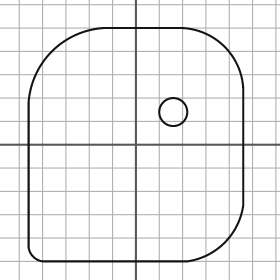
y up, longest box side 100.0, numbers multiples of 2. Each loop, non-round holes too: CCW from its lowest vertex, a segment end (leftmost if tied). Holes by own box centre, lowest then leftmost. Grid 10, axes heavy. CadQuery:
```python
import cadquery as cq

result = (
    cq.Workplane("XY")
    .moveTo(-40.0, -50.0)
    .lineTo(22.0, -50.0)
    .threePointArc((38.0, -42.0), (46.0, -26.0))
    .lineTo(46.0, 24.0)
    .threePointArc((38.0, 42.0), (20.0, 50.0))
    .lineTo(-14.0, 50.0)
    .threePointArc((-36.0, 40.0), (-46.0, 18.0))
    .lineTo(-46.0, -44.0)
    .threePointArc((-44.0, -48.0), (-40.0, -50.0))
    .close()
    .moveTo(16.0, 14.0)
    .circle(6.0)
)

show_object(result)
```